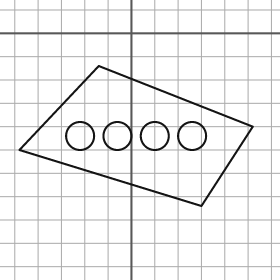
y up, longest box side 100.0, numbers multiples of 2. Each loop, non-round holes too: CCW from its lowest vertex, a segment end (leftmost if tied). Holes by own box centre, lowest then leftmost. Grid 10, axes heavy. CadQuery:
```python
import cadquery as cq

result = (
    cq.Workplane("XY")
    .moveTo(30.0, -74.0)
    .lineTo(52.0, -40.0)
    .lineTo(-14.0, -14.0)
    .lineTo(-48.0, -50.0)
    .close()
    .moveTo(-22.0, -44.0)
    .circle(6.0)
    .moveTo(-6.0, -44.0)
    .circle(6.0)
    .moveTo(10.0, -44.0)
    .circle(6.0)
    .moveTo(26.0, -44.0)
    .circle(6.0)
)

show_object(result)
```